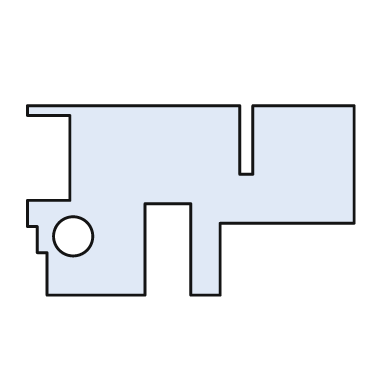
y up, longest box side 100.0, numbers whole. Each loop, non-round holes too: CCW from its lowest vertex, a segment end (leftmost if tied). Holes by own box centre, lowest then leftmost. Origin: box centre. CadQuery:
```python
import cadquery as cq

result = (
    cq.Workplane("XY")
    .moveTo(-44.0, -29.0)
    .lineTo(-14.0, -29.0)
    .lineTo(-14.0, -1.0)
    .lineTo(0.0, -1.0)
    .lineTo(0.0, -29.0)
    .lineTo(9.0, -29.0)
    .lineTo(9.0, -7.0)
    .lineTo(50.0, -7.0)
    .lineTo(50.0, 29.0)
    .lineTo(19.0, 29.0)
    .lineTo(19.0, 8.0)
    .lineTo(15.0, 8.0)
    .lineTo(15.0, 29.0)
    .lineTo(-50.0, 29.0)
    .lineTo(-50.0, 26.0)
    .lineTo(-37.0, 26.0)
    .lineTo(-37.0, 0.0)
    .lineTo(-50.0, 0.0)
    .lineTo(-50.0, -8.0)
    .lineTo(-47.0, -8.0)
    .lineTo(-47.0, -16.0)
    .lineTo(-44.0, -16.0)
    .close()
    .moveTo(-36.0, -11.0)
    .circle(6.0)
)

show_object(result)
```